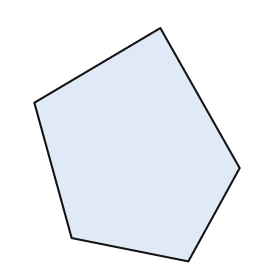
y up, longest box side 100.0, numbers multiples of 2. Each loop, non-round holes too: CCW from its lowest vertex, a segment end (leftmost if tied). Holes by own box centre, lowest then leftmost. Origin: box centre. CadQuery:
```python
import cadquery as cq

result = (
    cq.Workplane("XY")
    .moveTo(22.0, -50.0)
    .lineTo(44.0, -10.0)
    .lineTo(10.0, 50.0)
    .lineTo(-44.0, 18.0)
    .lineTo(-28.0, -40.0)
    .close()
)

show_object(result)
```